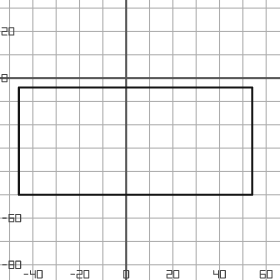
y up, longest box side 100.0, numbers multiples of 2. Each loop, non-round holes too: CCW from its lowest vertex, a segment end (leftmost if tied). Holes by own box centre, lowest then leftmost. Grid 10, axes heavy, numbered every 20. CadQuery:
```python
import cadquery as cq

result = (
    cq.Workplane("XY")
    .moveTo(-46.0, -50.0)
    .lineTo(54.0, -50.0)
    .lineTo(54.0, -4.0)
    .lineTo(-46.0, -4.0)
    .close()
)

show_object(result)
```